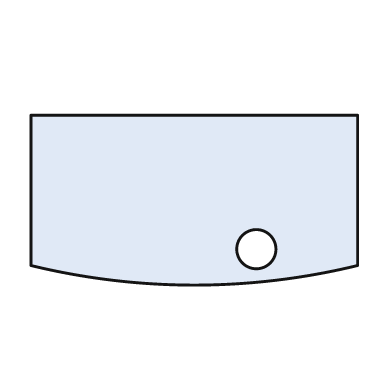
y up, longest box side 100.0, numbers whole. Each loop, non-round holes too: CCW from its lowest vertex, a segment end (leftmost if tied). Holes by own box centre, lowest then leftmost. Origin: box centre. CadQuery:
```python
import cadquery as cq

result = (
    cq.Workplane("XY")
    .moveTo(-50.0, -20.0)
    .threePointArc((0.0, -26.0), (50.0, -20.0))
    .lineTo(50.0, 26.0)
    .lineTo(-50.0, 26.0)
    .close()
    .moveTo(19.0, -15.0)
    .circle(6.0)
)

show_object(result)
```